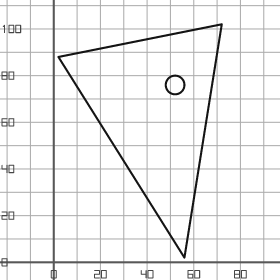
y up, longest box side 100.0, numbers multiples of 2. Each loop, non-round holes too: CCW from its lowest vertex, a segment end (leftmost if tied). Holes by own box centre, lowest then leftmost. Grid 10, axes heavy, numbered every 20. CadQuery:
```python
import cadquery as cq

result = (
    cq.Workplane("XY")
    .moveTo(56.0, 2.0)
    .lineTo(72.0, 102.0)
    .lineTo(2.0, 88.0)
    .close()
    .moveTo(52.0, 76.0)
    .circle(4.0)
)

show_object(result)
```